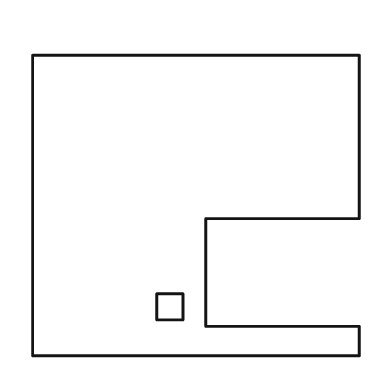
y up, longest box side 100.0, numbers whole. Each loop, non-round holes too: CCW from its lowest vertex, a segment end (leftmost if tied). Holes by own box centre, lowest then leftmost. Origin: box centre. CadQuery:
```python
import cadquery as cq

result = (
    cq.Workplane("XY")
    .moveTo(-50.0, -46.0)
    .lineTo(50.0, -46.0)
    .lineTo(50.0, -37.0)
    .lineTo(3.0, -37.0)
    .lineTo(3.0, -4.0)
    .lineTo(50.0, -4.0)
    .lineTo(50.0, 46.0)
    .lineTo(-50.0, 46.0)
    .close()
    .moveTo(-12.0, -35.0)
    .lineTo(-4.0, -35.0)
    .lineTo(-4.0, -27.0)
    .lineTo(-12.0, -27.0)
    .close()
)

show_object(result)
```